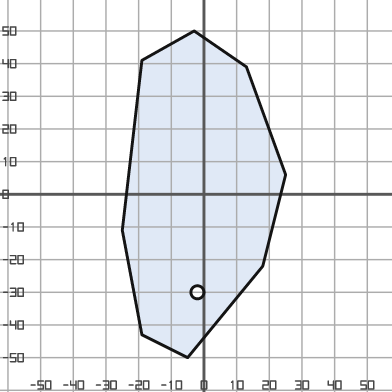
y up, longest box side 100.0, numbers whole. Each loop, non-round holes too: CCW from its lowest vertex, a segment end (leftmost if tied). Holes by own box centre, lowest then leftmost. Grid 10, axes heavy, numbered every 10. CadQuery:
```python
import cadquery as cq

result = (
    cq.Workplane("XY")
    .moveTo(-5.0, -50.0)
    .lineTo(18.0, -22.0)
    .lineTo(25.0, 6.0)
    .lineTo(13.0, 39.0)
    .lineTo(-3.0, 50.0)
    .lineTo(-19.0, 41.0)
    .lineTo(-25.0, -11.0)
    .lineTo(-19.0, -43.0)
    .close()
    .moveTo(-2.0, -30.0)
    .circle(2.0)
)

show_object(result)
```